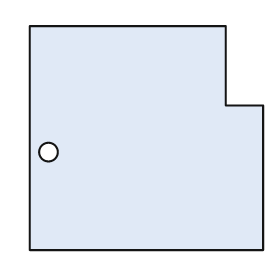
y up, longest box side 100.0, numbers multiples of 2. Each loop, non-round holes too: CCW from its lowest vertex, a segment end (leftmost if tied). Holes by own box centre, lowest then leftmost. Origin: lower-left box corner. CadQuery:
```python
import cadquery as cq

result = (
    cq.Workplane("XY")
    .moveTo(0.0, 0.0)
    .lineTo(100.0, 0.0)
    .lineTo(100.0, 62.0)
    .lineTo(84.0, 62.0)
    .lineTo(84.0, 96.0)
    .lineTo(0.0, 96.0)
    .close()
    .moveTo(8.0, 42.0)
    .circle(4.0)
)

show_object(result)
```